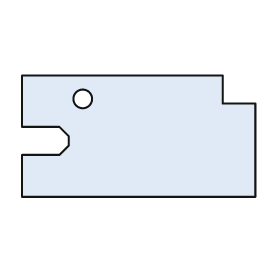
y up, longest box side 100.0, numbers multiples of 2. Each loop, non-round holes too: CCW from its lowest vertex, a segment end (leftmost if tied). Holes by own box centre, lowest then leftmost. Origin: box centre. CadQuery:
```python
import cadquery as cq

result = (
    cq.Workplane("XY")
    .moveTo(-50.0, -26.0)
    .lineTo(50.0, -26.0)
    .lineTo(50.0, 14.0)
    .lineTo(36.0, 14.0)
    .lineTo(36.0, 26.0)
    .lineTo(-50.0, 26.0)
    .lineTo(-50.0, 4.0)
    .lineTo(-34.0, 4.0)
    .lineTo(-30.0, 0.0)
    .lineTo(-30.0, -4.0)
    .lineTo(-34.0, -8.0)
    .lineTo(-50.0, -8.0)
    .close()
    .moveTo(-24.0, 16.0)
    .circle(4.0)
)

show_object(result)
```